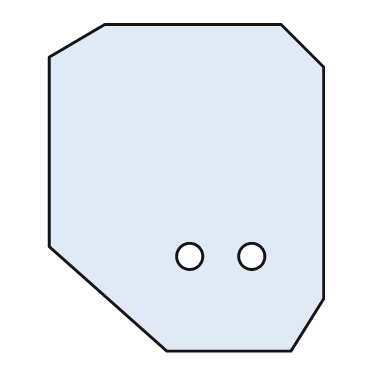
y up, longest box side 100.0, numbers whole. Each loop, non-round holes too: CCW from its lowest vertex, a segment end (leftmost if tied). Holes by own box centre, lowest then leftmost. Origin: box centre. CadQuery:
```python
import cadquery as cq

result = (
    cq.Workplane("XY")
    .moveTo(-6.0, -50.0)
    .lineTo(32.0, -50.0)
    .lineTo(42.0, -34.0)
    .lineTo(42.0, 37.0)
    .lineTo(29.0, 50.0)
    .lineTo(-25.0, 50.0)
    .lineTo(-42.0, 40.0)
    .lineTo(-42.0, -18.0)
    .close()
    .moveTo(1.0, -21.0)
    .circle(4.0)
    .moveTo(20.0, -21.0)
    .circle(4.0)
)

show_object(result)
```